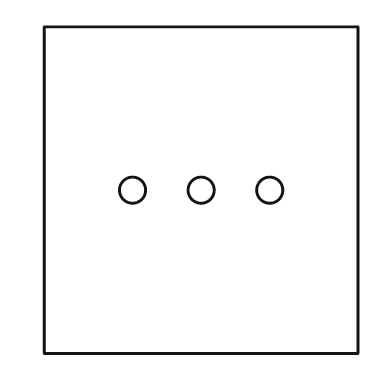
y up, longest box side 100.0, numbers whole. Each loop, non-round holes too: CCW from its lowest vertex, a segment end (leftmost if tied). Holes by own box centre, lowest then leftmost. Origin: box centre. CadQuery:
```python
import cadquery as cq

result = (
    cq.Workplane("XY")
    .moveTo(-48.0, -50.0)
    .lineTo(48.0, -50.0)
    .lineTo(48.0, 50.0)
    .lineTo(-48.0, 50.0)
    .close()
    .moveTo(-21.0, 0.0)
    .circle(4.0)
    .moveTo(0.0, 0.0)
    .circle(4.0)
    .moveTo(21.0, 0.0)
    .circle(4.0)
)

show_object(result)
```